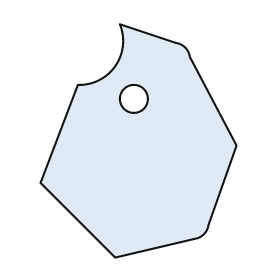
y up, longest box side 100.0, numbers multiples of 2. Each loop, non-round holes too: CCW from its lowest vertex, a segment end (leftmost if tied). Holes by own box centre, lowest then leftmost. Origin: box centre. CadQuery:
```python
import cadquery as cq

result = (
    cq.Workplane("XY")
    .moveTo(-10.0, -50.0)
    .lineTo(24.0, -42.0)
    .threePointArc((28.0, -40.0), (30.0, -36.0))
    .lineTo(42.0, -2.0)
    .lineTo(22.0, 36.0)
    .threePointArc((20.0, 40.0), (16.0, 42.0))
    .lineTo(-8.0, 50.0)
    .threePointArc((-10.0, 32.0), (-26.0, 24.0))
    .lineTo(-42.0, -18.0)
    .close()
    .moveTo(-2.0, 18.0)
    .circle(6.0)
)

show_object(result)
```